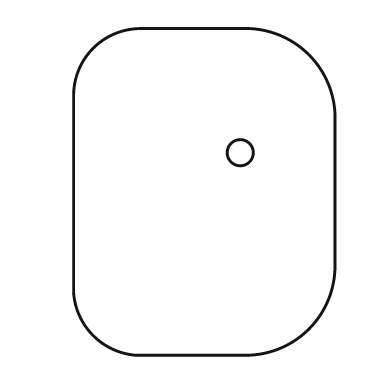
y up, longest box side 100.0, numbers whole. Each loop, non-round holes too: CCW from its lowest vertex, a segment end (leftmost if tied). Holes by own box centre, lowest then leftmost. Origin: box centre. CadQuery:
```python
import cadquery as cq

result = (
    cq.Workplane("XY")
    .moveTo(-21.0, -50.0)
    .lineTo(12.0, -50.0)
    .threePointArc((32.0, -42.0), (40.0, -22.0))
    .lineTo(40.0, 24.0)
    .threePointArc((32.0, 42.0), (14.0, 50.0))
    .lineTo(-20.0, 50.0)
    .threePointArc((-34.0, 44.0), (-40.0, 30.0))
    .lineTo(-40.0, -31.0)
    .threePointArc((-34.0, -44.0), (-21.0, -50.0))
    .close()
    .moveTo(11.0, 12.0)
    .circle(4.0)
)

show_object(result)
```